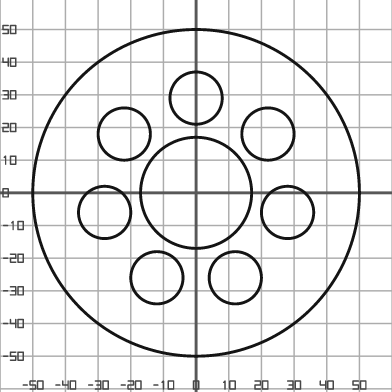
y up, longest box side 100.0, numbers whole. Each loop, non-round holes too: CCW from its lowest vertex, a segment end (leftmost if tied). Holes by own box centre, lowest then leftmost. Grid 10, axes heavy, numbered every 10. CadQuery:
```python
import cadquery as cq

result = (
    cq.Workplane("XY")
    .moveTo(0.0, 0.0)
    .circle(50.0)
    .moveTo(-12.0, -26.0)
    .circle(8.0)
    .moveTo(12.0, -26.0)
    .circle(8.0)
    .moveTo(-28.0, -6.0)
    .circle(8.0)
    .moveTo(28.0, -6.0)
    .circle(8.0)
    .moveTo(0.0, 0.0)
    .circle(17.0)
    .moveTo(-22.0, 18.0)
    .circle(8.0)
    .moveTo(22.0, 18.0)
    .circle(8.0)
    .moveTo(0.0, 29.0)
    .circle(8.0)
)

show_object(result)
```